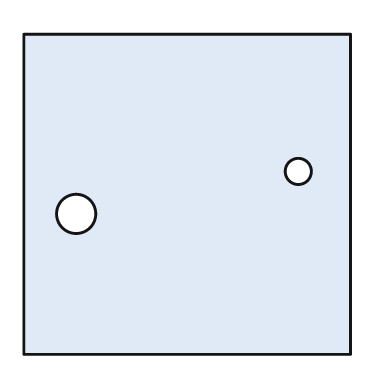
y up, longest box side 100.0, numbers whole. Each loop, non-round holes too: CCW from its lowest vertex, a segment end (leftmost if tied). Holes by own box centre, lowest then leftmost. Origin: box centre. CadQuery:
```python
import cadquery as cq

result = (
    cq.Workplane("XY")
    .moveTo(-50.0, -49.0)
    .lineTo(50.0, -49.0)
    .lineTo(50.0, 49.0)
    .lineTo(-50.0, 49.0)
    .close()
    .moveTo(-34.0, -6.0)
    .circle(6.0)
    .moveTo(34.0, 7.0)
    .circle(4.0)
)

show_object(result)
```